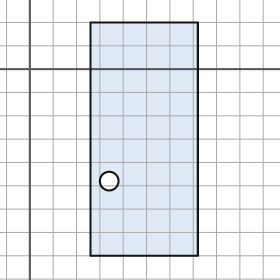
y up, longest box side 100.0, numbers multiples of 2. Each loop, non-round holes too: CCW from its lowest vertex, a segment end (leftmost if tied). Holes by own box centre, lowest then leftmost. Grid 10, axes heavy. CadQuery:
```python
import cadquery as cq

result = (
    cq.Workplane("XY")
    .moveTo(26.0, -80.0)
    .lineTo(72.0, -80.0)
    .lineTo(72.0, 20.0)
    .lineTo(26.0, 20.0)
    .close()
    .moveTo(34.0, -48.0)
    .circle(4.0)
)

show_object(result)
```